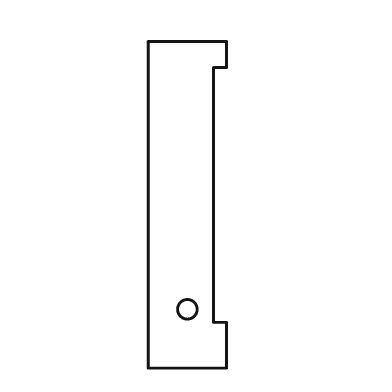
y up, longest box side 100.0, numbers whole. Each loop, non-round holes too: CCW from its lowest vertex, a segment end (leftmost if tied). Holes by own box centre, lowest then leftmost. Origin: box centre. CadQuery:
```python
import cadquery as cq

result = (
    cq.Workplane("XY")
    .moveTo(-12.0, -50.0)
    .lineTo(12.0, -50.0)
    .lineTo(12.0, -36.0)
    .lineTo(8.0, -36.0)
    .lineTo(8.0, 42.0)
    .lineTo(12.0, 42.0)
    .lineTo(12.0, 50.0)
    .lineTo(-12.0, 50.0)
    .close()
    .moveTo(0.0, -32.0)
    .circle(3.0)
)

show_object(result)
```